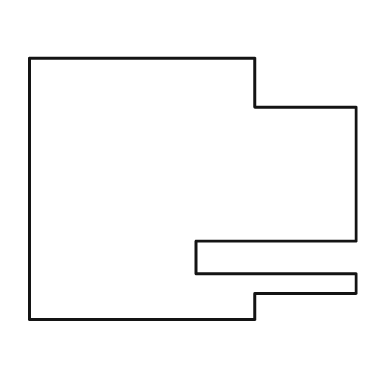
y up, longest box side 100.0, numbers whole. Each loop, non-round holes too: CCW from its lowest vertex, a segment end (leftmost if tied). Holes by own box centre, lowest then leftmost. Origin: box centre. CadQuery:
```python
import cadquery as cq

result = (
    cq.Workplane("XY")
    .moveTo(-50.0, -40.0)
    .lineTo(19.0, -40.0)
    .lineTo(19.0, -32.0)
    .lineTo(50.0, -32.0)
    .lineTo(50.0, -26.0)
    .lineTo(1.0, -26.0)
    .lineTo(1.0, -16.0)
    .lineTo(50.0, -16.0)
    .lineTo(50.0, 25.0)
    .lineTo(19.0, 25.0)
    .lineTo(19.0, 40.0)
    .lineTo(-50.0, 40.0)
    .close()
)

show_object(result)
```